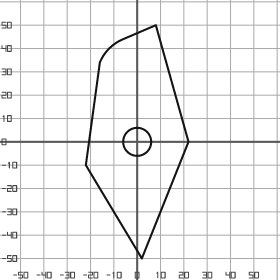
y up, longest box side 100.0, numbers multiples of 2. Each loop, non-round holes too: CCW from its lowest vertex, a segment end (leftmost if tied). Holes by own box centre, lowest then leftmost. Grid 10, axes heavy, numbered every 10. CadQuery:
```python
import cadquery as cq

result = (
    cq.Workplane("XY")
    .moveTo(2.0, -50.0)
    .lineTo(22.0, 0.0)
    .lineTo(8.0, 50.0)
    .lineTo(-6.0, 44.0)
    .threePointArc((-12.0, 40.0), (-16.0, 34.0))
    .lineTo(-22.0, -10.0)
    .close()
    .moveTo(0.0, 0.0)
    .circle(6.0)
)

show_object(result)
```